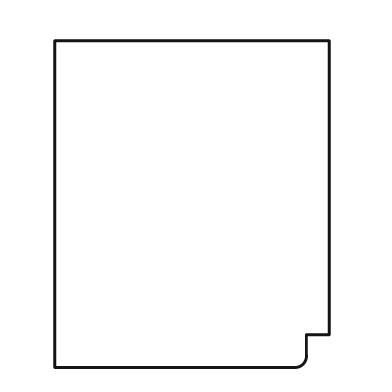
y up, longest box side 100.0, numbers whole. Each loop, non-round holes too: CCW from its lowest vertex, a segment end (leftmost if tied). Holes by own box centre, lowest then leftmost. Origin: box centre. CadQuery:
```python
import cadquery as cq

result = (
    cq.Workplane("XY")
    .moveTo(-42.0, -50.0)
    .lineTo(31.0, -50.0)
    .threePointArc((34.0, -49.0), (35.0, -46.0))
    .lineTo(35.0, -40.0)
    .lineTo(42.0, -40.0)
    .lineTo(42.0, 50.0)
    .lineTo(-42.0, 50.0)
    .close()
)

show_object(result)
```